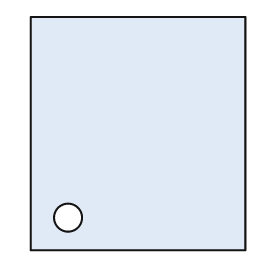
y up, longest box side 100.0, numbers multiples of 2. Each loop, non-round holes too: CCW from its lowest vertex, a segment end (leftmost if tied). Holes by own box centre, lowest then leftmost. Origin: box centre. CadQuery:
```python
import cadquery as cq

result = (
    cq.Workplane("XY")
    .moveTo(-46.0, -50.0)
    .lineTo(46.0, -50.0)
    .lineTo(46.0, 50.0)
    .lineTo(-46.0, 50.0)
    .close()
    .moveTo(-30.0, -36.0)
    .circle(6.0)
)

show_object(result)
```